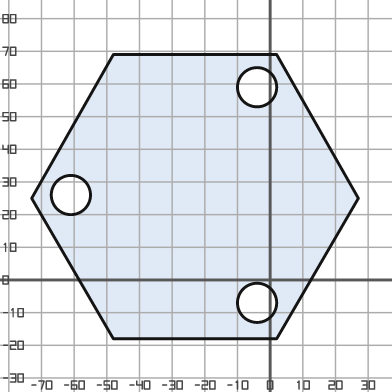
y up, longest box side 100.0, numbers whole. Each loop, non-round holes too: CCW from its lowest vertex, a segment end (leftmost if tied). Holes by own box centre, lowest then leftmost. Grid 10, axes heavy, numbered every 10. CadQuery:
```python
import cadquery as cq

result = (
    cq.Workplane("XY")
    .moveTo(-48.0, -18.0)
    .lineTo(2.0, -18.0)
    .lineTo(27.0, 25.0)
    .lineTo(2.0, 69.0)
    .lineTo(-48.0, 69.0)
    .lineTo(-73.0, 25.0)
    .close()
    .moveTo(-4.0, -7.0)
    .circle(6.0)
    .moveTo(-61.0, 26.0)
    .circle(6.0)
    .moveTo(-4.0, 59.0)
    .circle(6.0)
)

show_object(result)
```